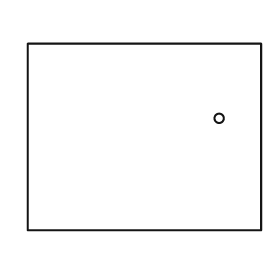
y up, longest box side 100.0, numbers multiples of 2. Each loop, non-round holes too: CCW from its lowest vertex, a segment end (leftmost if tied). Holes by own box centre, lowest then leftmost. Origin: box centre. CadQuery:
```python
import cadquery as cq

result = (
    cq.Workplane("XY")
    .moveTo(-50.0, -40.0)
    .lineTo(50.0, -40.0)
    .lineTo(50.0, 40.0)
    .lineTo(-50.0, 40.0)
    .close()
    .moveTo(32.0, 8.0)
    .circle(2.0)
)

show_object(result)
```